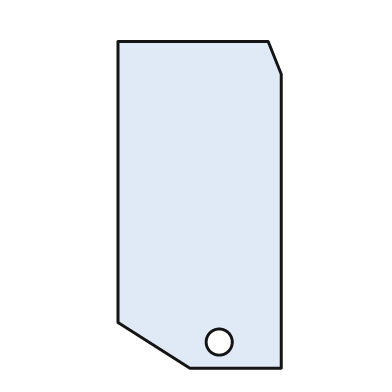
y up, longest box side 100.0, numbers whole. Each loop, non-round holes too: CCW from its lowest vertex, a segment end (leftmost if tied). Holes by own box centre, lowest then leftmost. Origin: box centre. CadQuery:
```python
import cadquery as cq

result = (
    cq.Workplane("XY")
    .moveTo(-3.0, -50.0)
    .lineTo(25.0, -50.0)
    .lineTo(25.0, 40.0)
    .lineTo(21.0, 50.0)
    .lineTo(-25.0, 50.0)
    .lineTo(-25.0, -36.0)
    .close()
    .moveTo(6.0, -42.0)
    .circle(4.0)
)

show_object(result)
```